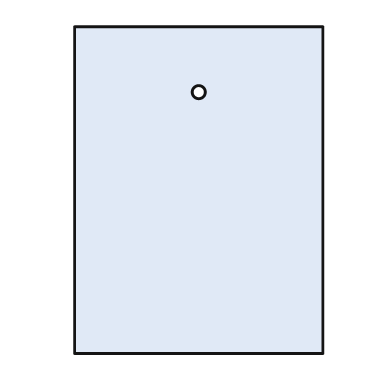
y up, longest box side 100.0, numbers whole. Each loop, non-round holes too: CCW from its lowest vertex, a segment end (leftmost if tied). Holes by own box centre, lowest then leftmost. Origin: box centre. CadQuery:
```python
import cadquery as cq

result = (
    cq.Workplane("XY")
    .moveTo(-38.0, -50.0)
    .lineTo(38.0, -50.0)
    .lineTo(38.0, 50.0)
    .lineTo(-38.0, 50.0)
    .close()
    .moveTo(0.0, 30.0)
    .circle(2.0)
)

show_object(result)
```